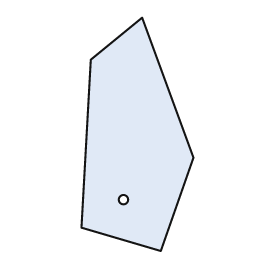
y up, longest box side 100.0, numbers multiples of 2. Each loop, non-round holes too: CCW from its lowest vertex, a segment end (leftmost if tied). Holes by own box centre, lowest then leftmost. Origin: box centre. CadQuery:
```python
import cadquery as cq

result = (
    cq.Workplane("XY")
    .moveTo(10.0, -50.0)
    .lineTo(24.0, -10.0)
    .lineTo(2.0, 50.0)
    .lineTo(-20.0, 32.0)
    .lineTo(-24.0, -40.0)
    .close()
    .moveTo(-6.0, -28.0)
    .circle(2.0)
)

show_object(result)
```